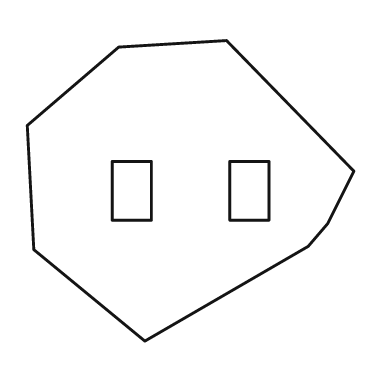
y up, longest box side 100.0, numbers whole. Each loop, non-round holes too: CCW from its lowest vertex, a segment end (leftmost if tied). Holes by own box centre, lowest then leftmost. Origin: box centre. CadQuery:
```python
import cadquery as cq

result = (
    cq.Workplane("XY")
    .moveTo(-14.0, -46.0)
    .lineTo(36.0, -17.0)
    .lineTo(42.0, -10.0)
    .lineTo(50.0, 6.0)
    .lineTo(11.0, 46.0)
    .lineTo(-22.0, 44.0)
    .lineTo(-50.0, 20.0)
    .lineTo(-48.0, -18.0)
    .close()
    .moveTo(-24.0, -9.0)
    .lineTo(-12.0, -9.0)
    .lineTo(-12.0, 9.0)
    .lineTo(-24.0, 9.0)
    .close()
    .moveTo(12.0, -9.0)
    .lineTo(24.0, -9.0)
    .lineTo(24.0, 9.0)
    .lineTo(12.0, 9.0)
    .close()
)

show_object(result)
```